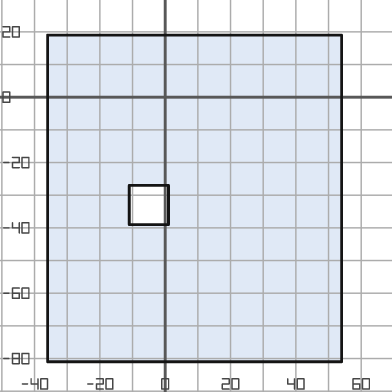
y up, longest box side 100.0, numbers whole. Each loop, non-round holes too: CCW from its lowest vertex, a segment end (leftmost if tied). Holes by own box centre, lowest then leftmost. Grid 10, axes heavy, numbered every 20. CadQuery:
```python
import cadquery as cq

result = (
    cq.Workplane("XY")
    .moveTo(-36.0, -81.0)
    .lineTo(54.0, -81.0)
    .lineTo(54.0, 19.0)
    .lineTo(-36.0, 19.0)
    .close()
    .moveTo(-11.0, -39.0)
    .lineTo(1.0, -39.0)
    .lineTo(1.0, -27.0)
    .lineTo(-11.0, -27.0)
    .close()
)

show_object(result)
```